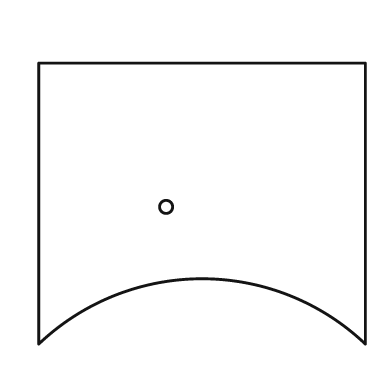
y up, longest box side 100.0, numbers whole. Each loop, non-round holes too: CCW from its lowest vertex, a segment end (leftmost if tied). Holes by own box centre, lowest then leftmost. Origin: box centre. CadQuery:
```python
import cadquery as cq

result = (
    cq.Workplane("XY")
    .moveTo(-50.0, -43.0)
    .threePointArc((0.0, -23.0), (50.0, -43.0))
    .lineTo(50.0, 43.0)
    .lineTo(-50.0, 43.0)
    .close()
    .moveTo(-11.0, -1.0)
    .circle(2.0)
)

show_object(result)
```